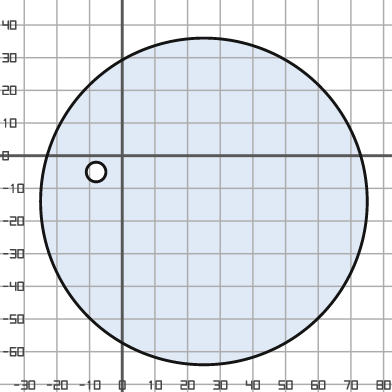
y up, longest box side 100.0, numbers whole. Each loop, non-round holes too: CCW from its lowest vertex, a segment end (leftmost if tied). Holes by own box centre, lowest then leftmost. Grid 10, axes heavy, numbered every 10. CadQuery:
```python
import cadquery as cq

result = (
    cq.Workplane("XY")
    .moveTo(25.0, -14.0)
    .circle(50.0)
    .moveTo(-8.0, -5.0)
    .circle(3.0)
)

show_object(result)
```